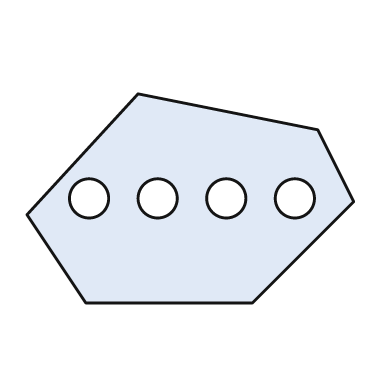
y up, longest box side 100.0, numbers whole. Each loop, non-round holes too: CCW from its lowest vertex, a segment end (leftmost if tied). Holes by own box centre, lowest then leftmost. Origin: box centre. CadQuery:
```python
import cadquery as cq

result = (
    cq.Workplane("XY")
    .moveTo(-32.0, -32.0)
    .lineTo(19.0, -32.0)
    .lineTo(50.0, -1.0)
    .lineTo(39.0, 21.0)
    .lineTo(-16.0, 32.0)
    .lineTo(-50.0, -5.0)
    .close()
    .moveTo(-31.0, 0.0)
    .circle(6.0)
    .moveTo(-10.0, 0.0)
    .circle(6.0)
    .moveTo(11.0, 0.0)
    .circle(6.0)
    .moveTo(32.0, 0.0)
    .circle(6.0)
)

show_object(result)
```